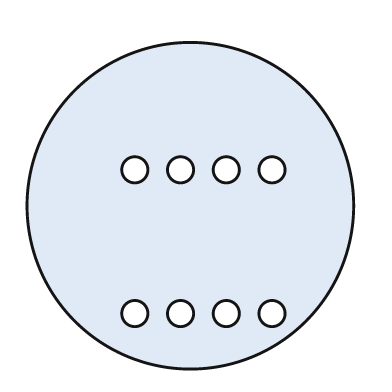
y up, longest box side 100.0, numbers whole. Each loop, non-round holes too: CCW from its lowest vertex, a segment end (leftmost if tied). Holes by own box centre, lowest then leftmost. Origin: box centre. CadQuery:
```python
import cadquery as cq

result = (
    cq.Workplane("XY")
    .moveTo(0.0, 0.0)
    .circle(50.0)
    .moveTo(-17.0, -33.0)
    .circle(4.0)
    .moveTo(-3.0, -33.0)
    .circle(4.0)
    .moveTo(11.0, -33.0)
    .circle(4.0)
    .moveTo(25.0, -33.0)
    .circle(4.0)
    .moveTo(-17.0, 11.0)
    .circle(4.0)
    .moveTo(-3.0, 11.0)
    .circle(4.0)
    .moveTo(11.0, 11.0)
    .circle(4.0)
    .moveTo(25.0, 11.0)
    .circle(4.0)
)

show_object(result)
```